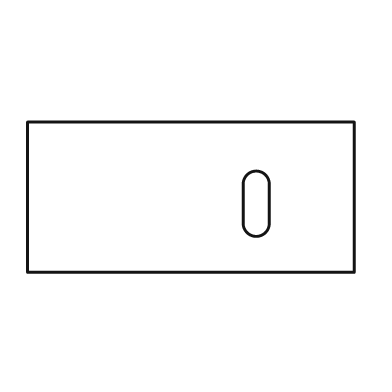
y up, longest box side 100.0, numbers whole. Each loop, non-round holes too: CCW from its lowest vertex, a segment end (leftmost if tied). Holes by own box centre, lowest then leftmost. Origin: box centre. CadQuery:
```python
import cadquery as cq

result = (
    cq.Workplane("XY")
    .moveTo(-50.0, -23.0)
    .lineTo(50.0, -23.0)
    .lineTo(50.0, 23.0)
    .lineTo(-50.0, 23.0)
    .close()
    .moveTo(16.0, -8.0)
    .threePointArc((20.0, -12.0), (24.0, -8.0))
    .lineTo(24.0, 4.0)
    .threePointArc((20.0, 8.0), (16.0, 4.0))
    .close()
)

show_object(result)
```